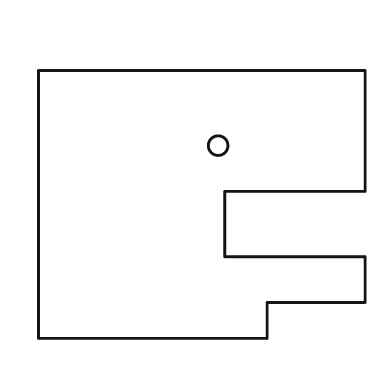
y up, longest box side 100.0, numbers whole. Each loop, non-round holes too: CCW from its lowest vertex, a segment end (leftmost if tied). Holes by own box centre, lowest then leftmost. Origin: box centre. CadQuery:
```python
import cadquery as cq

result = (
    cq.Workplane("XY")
    .moveTo(-50.0, -41.0)
    .lineTo(20.0, -41.0)
    .lineTo(20.0, -30.0)
    .lineTo(50.0, -30.0)
    .lineTo(50.0, -16.0)
    .lineTo(7.0, -16.0)
    .lineTo(7.0, 4.0)
    .lineTo(50.0, 4.0)
    .lineTo(50.0, 41.0)
    .lineTo(-50.0, 41.0)
    .close()
    .moveTo(5.0, 18.0)
    .circle(3.0)
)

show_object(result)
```